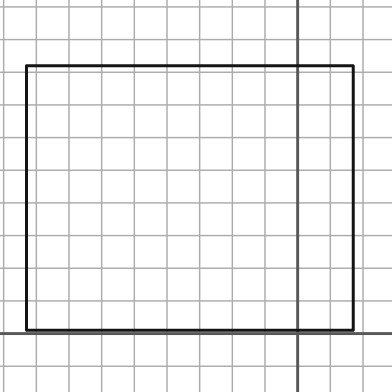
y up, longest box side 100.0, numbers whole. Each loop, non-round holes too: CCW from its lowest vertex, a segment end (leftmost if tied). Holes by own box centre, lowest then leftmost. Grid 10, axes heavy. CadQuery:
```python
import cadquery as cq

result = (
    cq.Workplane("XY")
    .moveTo(-83.0, 1.0)
    .lineTo(17.0, 1.0)
    .lineTo(17.0, 82.0)
    .lineTo(-83.0, 82.0)
    .close()
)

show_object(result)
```